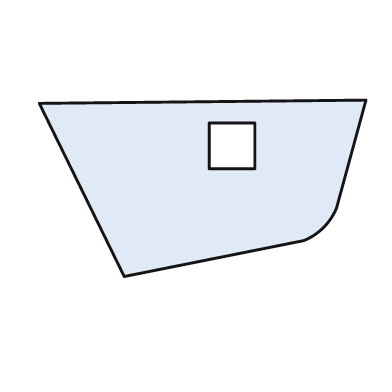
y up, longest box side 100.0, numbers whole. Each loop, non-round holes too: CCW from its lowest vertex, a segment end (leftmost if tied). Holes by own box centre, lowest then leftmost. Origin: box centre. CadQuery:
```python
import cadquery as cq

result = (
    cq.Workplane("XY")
    .moveTo(-24.0, -27.0)
    .lineTo(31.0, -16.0)
    .threePointArc((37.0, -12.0), (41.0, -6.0))
    .lineTo(50.0, 27.0)
    .lineTo(-50.0, 26.0)
    .close()
    .moveTo(2.0, 6.0)
    .lineTo(16.0, 6.0)
    .lineTo(16.0, 20.0)
    .lineTo(2.0, 20.0)
    .close()
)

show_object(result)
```